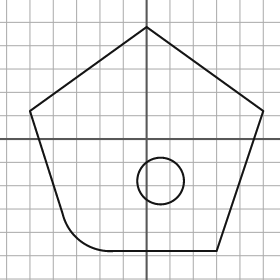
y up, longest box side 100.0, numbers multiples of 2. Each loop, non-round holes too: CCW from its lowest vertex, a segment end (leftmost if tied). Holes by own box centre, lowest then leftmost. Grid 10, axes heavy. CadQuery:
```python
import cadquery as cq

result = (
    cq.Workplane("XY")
    .moveTo(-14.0, -48.0)
    .lineTo(30.0, -48.0)
    .lineTo(50.0, 12.0)
    .lineTo(0.0, 48.0)
    .lineTo(-50.0, 12.0)
    .lineTo(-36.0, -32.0)
    .threePointArc((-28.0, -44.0), (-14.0, -48.0))
    .close()
    .moveTo(6.0, -18.0)
    .circle(10.0)
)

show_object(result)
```